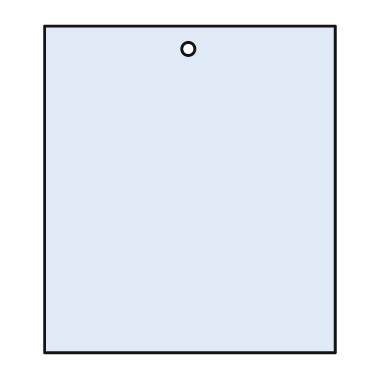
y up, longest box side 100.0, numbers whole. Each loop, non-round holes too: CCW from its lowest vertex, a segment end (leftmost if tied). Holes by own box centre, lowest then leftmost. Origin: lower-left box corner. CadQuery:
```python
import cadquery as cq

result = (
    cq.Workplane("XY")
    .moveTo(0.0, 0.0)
    .lineTo(89.0, 0.0)
    .lineTo(89.0, 100.0)
    .lineTo(0.0, 100.0)
    .close()
    .moveTo(44.0, 93.0)
    .circle(2.0)
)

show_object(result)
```